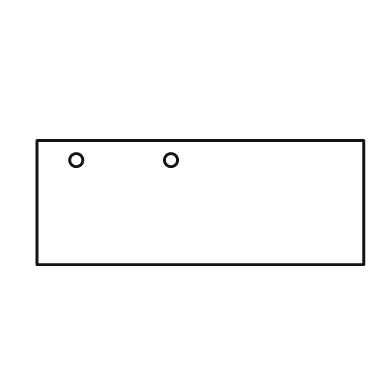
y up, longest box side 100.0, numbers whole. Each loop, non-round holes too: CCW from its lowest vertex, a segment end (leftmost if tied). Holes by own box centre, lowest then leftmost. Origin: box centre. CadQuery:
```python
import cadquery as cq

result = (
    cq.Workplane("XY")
    .moveTo(-50.0, -19.0)
    .lineTo(50.0, -19.0)
    .lineTo(50.0, 19.0)
    .lineTo(-50.0, 19.0)
    .close()
    .moveTo(-38.0, 13.0)
    .circle(2.0)
    .moveTo(-9.0, 13.0)
    .circle(2.0)
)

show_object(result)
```